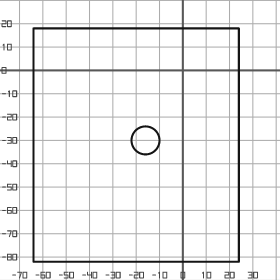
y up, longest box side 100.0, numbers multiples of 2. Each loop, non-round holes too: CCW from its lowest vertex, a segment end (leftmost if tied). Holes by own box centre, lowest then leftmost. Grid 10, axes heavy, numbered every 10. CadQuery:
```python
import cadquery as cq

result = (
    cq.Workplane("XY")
    .moveTo(-64.0, -82.0)
    .lineTo(24.0, -82.0)
    .lineTo(24.0, 18.0)
    .lineTo(-64.0, 18.0)
    .close()
    .moveTo(-16.0, -30.0)
    .circle(6.0)
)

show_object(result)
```